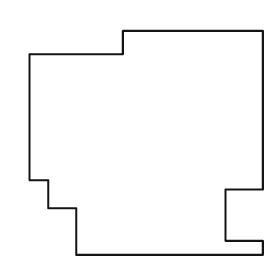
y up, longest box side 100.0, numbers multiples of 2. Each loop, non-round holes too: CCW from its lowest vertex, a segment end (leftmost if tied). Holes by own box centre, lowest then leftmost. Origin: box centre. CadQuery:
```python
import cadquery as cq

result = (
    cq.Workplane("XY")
    .moveTo(-30.0, -48.0)
    .lineTo(50.0, -48.0)
    .lineTo(50.0, -42.0)
    .lineTo(34.0, -42.0)
    .lineTo(34.0, -20.0)
    .lineTo(50.0, -20.0)
    .lineTo(50.0, 48.0)
    .lineTo(-10.0, 48.0)
    .lineTo(-10.0, 38.0)
    .lineTo(-50.0, 38.0)
    .lineTo(-50.0, -16.0)
    .lineTo(-42.0, -16.0)
    .lineTo(-42.0, -28.0)
    .lineTo(-30.0, -28.0)
    .close()
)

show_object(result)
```